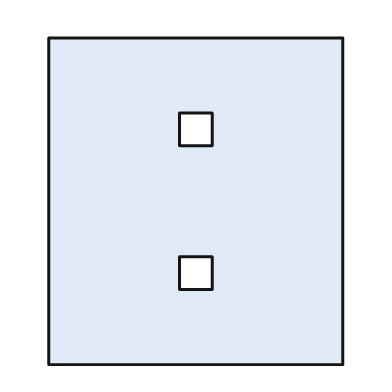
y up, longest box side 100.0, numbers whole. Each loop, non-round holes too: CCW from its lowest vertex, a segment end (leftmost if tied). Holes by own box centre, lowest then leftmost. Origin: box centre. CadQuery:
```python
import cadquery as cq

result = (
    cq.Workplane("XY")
    .moveTo(-45.0, -50.0)
    .lineTo(45.0, -50.0)
    .lineTo(45.0, 50.0)
    .lineTo(-45.0, 50.0)
    .close()
    .moveTo(-5.0, -27.0)
    .lineTo(5.0, -27.0)
    .lineTo(5.0, -17.0)
    .lineTo(-5.0, -17.0)
    .close()
    .moveTo(-5.0, 17.0)
    .lineTo(5.0, 17.0)
    .lineTo(5.0, 27.0)
    .lineTo(-5.0, 27.0)
    .close()
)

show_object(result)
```